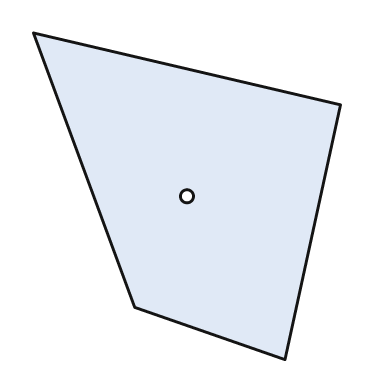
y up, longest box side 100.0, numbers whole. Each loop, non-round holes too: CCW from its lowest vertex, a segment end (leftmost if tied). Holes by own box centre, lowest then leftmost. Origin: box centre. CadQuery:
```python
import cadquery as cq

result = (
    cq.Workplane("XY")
    .moveTo(30.0, -50.0)
    .lineTo(47.0, 28.0)
    .lineTo(-47.0, 50.0)
    .lineTo(-16.0, -34.0)
    .close()
    .moveTo(0.0, 0.0)
    .circle(2.0)
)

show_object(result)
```